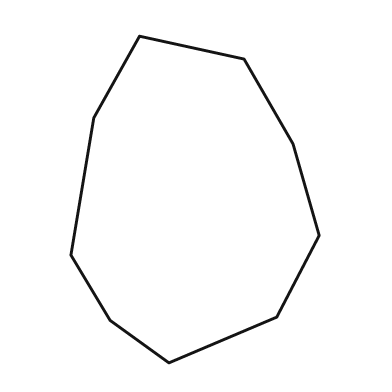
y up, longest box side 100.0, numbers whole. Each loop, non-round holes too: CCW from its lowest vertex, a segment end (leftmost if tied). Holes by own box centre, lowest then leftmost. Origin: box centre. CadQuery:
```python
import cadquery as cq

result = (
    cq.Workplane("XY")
    .moveTo(-8.0, -50.0)
    .lineTo(25.0, -36.0)
    .lineTo(38.0, -11.0)
    .lineTo(30.0, 17.0)
    .lineTo(15.0, 43.0)
    .lineTo(-17.0, 50.0)
    .lineTo(-31.0, 25.0)
    .lineTo(-38.0, -17.0)
    .lineTo(-26.0, -37.0)
    .close()
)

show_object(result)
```